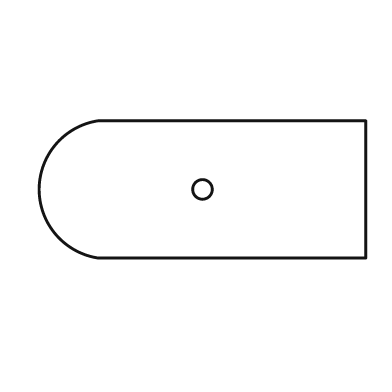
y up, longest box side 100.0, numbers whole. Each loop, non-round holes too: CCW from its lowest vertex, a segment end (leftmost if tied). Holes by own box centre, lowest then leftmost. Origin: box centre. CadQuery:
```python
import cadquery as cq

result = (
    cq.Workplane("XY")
    .moveTo(-32.0, -21.0)
    .lineTo(50.0, -21.0)
    .lineTo(50.0, 21.0)
    .lineTo(-32.0, 21.0)
    .threePointArc((-50.0, 0.0), (-32.0, -21.0))
    .close()
    .moveTo(0.0, 0.0)
    .circle(3.0)
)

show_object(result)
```